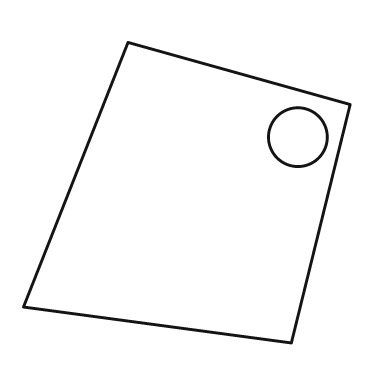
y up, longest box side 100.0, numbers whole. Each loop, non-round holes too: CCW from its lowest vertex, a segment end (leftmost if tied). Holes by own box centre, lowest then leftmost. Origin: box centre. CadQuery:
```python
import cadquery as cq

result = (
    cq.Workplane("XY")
    .moveTo(32.0, -46.0)
    .lineTo(50.0, 27.0)
    .lineTo(-18.0, 46.0)
    .lineTo(-50.0, -35.0)
    .close()
    .moveTo(34.0, 17.0)
    .circle(9.0)
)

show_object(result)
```